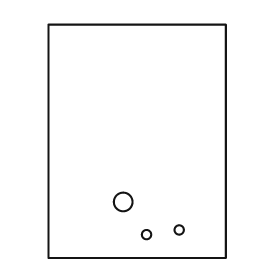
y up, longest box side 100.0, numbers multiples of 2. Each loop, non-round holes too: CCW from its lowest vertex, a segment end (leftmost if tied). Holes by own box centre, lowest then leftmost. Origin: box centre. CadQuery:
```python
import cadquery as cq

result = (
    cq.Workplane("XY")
    .moveTo(-38.0, -50.0)
    .lineTo(38.0, -50.0)
    .lineTo(38.0, 50.0)
    .lineTo(-38.0, 50.0)
    .close()
    .moveTo(4.0, -40.0)
    .circle(2.0)
    .moveTo(18.0, -38.0)
    .circle(2.0)
    .moveTo(-6.0, -26.0)
    .circle(4.0)
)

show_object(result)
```